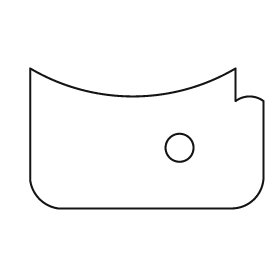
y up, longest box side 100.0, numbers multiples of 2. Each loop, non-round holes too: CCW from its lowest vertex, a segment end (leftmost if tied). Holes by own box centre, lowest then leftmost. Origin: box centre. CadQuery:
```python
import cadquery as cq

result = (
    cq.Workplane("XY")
    .moveTo(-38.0, -30.0)
    .lineTo(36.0, -30.0)
    .threePointArc((46.0, -26.0), (50.0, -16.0))
    .lineTo(50.0, 16.0)
    .threePointArc((44.0, 18.0), (38.0, 16.0))
    .lineTo(38.0, 30.0)
    .threePointArc((-6.0, 18.0), (-50.0, 30.0))
    .lineTo(-50.0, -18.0)
    .threePointArc((-46.0, -26.0), (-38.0, -30.0))
    .close()
    .moveTo(14.0, -4.0)
    .circle(6.0)
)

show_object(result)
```